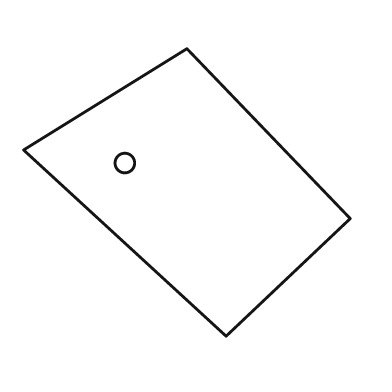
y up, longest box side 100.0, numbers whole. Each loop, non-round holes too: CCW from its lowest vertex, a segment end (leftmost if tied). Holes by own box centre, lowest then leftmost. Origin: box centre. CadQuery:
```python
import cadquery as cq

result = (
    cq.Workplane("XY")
    .moveTo(12.0, -44.0)
    .lineTo(50.0, -8.0)
    .lineTo(0.0, 44.0)
    .lineTo(-50.0, 13.0)
    .close()
    .moveTo(-19.0, 9.0)
    .circle(3.0)
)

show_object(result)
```